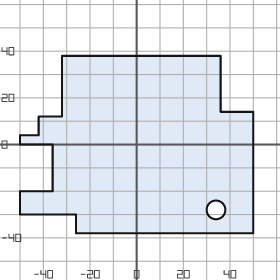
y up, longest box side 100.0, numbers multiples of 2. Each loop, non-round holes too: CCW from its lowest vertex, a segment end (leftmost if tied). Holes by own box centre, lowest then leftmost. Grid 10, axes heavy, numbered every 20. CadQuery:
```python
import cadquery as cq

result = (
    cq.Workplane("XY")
    .moveTo(-26.0, -38.0)
    .lineTo(50.0, -38.0)
    .lineTo(50.0, 14.0)
    .lineTo(36.0, 14.0)
    .lineTo(36.0, 38.0)
    .lineTo(-32.0, 38.0)
    .lineTo(-32.0, 12.0)
    .lineTo(-42.0, 12.0)
    .lineTo(-42.0, 4.0)
    .lineTo(-50.0, 4.0)
    .lineTo(-50.0, 0.0)
    .lineTo(-36.0, 0.0)
    .lineTo(-36.0, -20.0)
    .lineTo(-50.0, -20.0)
    .lineTo(-50.0, -30.0)
    .lineTo(-26.0, -30.0)
    .close()
    .moveTo(34.0, -28.0)
    .circle(4.0)
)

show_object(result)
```